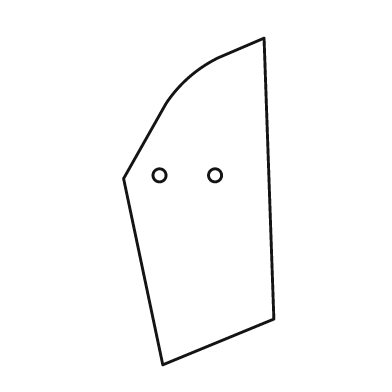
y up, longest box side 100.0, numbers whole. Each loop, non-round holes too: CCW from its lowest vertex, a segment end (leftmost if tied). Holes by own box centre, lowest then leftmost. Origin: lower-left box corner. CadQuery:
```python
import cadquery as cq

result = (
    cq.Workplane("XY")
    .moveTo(12.0, 0.0)
    .lineTo(46.0, 14.0)
    .lineTo(43.0, 100.0)
    .lineTo(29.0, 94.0)
    .threePointArc((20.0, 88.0), (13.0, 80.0))
    .lineTo(0.0, 57.0)
    .close()
    .moveTo(11.0, 58.0)
    .circle(2.0)
    .moveTo(28.0, 58.0)
    .circle(2.0)
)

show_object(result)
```